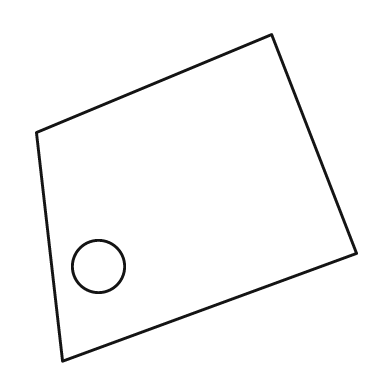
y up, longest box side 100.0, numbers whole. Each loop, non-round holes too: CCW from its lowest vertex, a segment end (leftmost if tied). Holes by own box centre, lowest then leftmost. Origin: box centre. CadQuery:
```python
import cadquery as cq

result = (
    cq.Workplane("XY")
    .moveTo(-41.0, -50.0)
    .lineTo(49.0, -17.0)
    .lineTo(23.0, 50.0)
    .lineTo(-49.0, 20.0)
    .close()
    .moveTo(-30.0, -21.0)
    .circle(8.0)
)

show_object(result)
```